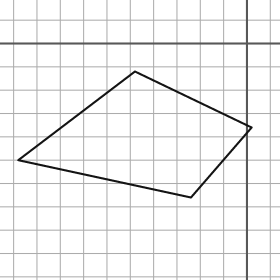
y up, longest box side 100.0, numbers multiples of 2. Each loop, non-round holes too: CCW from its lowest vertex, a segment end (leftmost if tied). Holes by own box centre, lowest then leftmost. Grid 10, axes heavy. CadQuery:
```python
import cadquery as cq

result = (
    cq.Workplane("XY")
    .moveTo(-24.0, -66.0)
    .lineTo(2.0, -36.0)
    .lineTo(-48.0, -12.0)
    .lineTo(-98.0, -50.0)
    .close()
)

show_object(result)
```